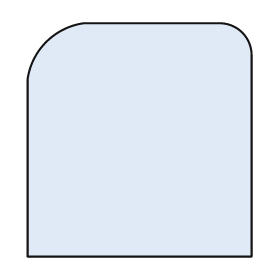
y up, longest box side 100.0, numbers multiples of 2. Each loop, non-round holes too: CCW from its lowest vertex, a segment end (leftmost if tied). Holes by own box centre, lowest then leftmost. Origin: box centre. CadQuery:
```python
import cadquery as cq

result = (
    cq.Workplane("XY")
    .moveTo(-48.0, -50.0)
    .lineTo(48.0, -50.0)
    .lineTo(48.0, 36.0)
    .threePointArc((44.0, 46.0), (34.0, 50.0))
    .lineTo(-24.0, 50.0)
    .threePointArc((-40.0, 42.0), (-48.0, 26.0))
    .close()
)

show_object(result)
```